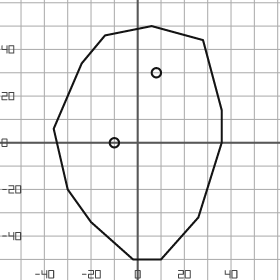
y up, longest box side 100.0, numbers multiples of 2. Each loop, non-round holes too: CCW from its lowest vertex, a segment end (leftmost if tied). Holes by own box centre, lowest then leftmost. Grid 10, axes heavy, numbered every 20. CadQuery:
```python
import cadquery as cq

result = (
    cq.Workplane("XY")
    .moveTo(-2.0, -50.0)
    .lineTo(10.0, -50.0)
    .lineTo(26.0, -32.0)
    .lineTo(36.0, 0.0)
    .lineTo(36.0, 14.0)
    .lineTo(28.0, 44.0)
    .lineTo(6.0, 50.0)
    .lineTo(-14.0, 46.0)
    .lineTo(-24.0, 34.0)
    .lineTo(-36.0, 6.0)
    .lineTo(-30.0, -20.0)
    .lineTo(-20.0, -34.0)
    .close()
    .moveTo(-10.0, 0.0)
    .circle(2.0)
    .moveTo(8.0, 30.0)
    .circle(2.0)
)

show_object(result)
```